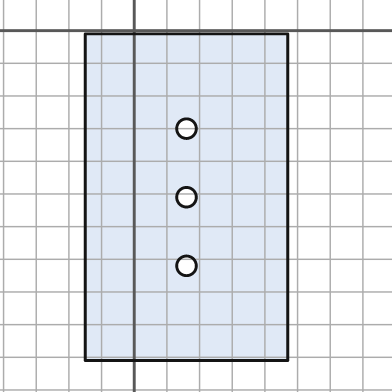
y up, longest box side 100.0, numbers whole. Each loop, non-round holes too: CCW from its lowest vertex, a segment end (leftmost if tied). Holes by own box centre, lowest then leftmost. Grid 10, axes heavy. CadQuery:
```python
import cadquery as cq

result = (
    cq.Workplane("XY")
    .moveTo(-15.0, -101.0)
    .lineTo(47.0, -101.0)
    .lineTo(47.0, -1.0)
    .lineTo(-15.0, -1.0)
    .close()
    .moveTo(16.0, -72.0)
    .circle(3.0)
    .moveTo(16.0, -51.0)
    .circle(3.0)
    .moveTo(16.0, -30.0)
    .circle(3.0)
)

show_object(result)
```